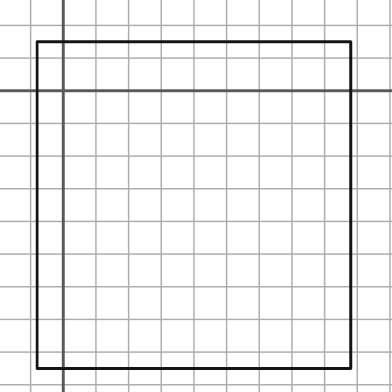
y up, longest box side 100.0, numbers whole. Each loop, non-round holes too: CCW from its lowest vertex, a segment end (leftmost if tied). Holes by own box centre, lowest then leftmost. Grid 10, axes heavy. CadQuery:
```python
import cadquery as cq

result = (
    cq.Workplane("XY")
    .moveTo(-8.0, -85.0)
    .lineTo(88.0, -85.0)
    .lineTo(88.0, 15.0)
    .lineTo(-8.0, 15.0)
    .close()
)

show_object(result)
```